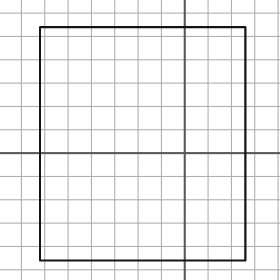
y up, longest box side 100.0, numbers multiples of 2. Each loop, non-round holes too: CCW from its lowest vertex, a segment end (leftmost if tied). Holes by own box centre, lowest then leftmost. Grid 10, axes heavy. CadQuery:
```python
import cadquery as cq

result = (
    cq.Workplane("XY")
    .moveTo(-62.0, -46.0)
    .lineTo(26.0, -46.0)
    .lineTo(26.0, 54.0)
    .lineTo(-62.0, 54.0)
    .close()
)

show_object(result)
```